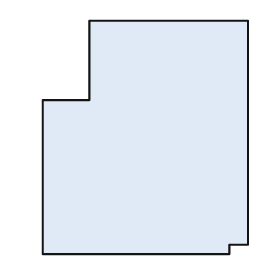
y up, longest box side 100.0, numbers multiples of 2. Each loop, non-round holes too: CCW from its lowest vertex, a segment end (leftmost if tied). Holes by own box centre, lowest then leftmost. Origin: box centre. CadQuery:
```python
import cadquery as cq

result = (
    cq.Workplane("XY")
    .moveTo(-44.0, -50.0)
    .lineTo(36.0, -50.0)
    .lineTo(36.0, -46.0)
    .lineTo(44.0, -46.0)
    .lineTo(44.0, 50.0)
    .lineTo(-24.0, 50.0)
    .lineTo(-24.0, 16.0)
    .lineTo(-44.0, 16.0)
    .close()
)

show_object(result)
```